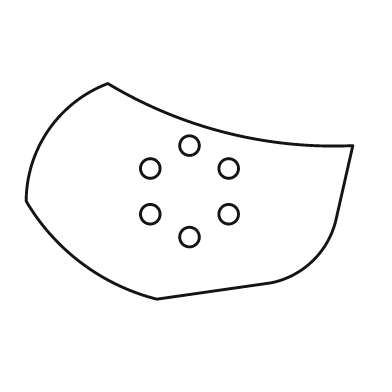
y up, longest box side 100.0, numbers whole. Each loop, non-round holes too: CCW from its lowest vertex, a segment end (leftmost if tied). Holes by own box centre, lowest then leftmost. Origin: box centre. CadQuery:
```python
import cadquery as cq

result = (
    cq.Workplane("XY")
    .moveTo(-10.0, -33.0)
    .lineTo(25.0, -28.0)
    .threePointArc((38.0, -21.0), (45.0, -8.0))
    .lineTo(50.0, 14.0)
    .threePointArc((11.0, 18.0), (-25.0, 33.0))
    .threePointArc((-43.0, 19.0), (-50.0, -3.0))
    .threePointArc((-33.0, -22.0), (-10.0, -33.0))
    .close()
    .moveTo(0.0, -14.0)
    .circle(3.0)
    .moveTo(-12.0, -7.0)
    .circle(3.0)
    .moveTo(12.0, -7.0)
    .circle(3.0)
    .moveTo(-12.0, 7.0)
    .circle(3.0)
    .moveTo(12.0, 7.0)
    .circle(3.0)
    .moveTo(0.0, 14.0)
    .circle(3.0)
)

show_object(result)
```